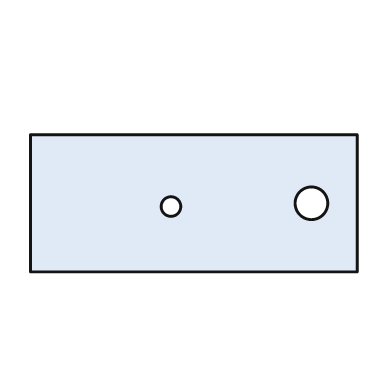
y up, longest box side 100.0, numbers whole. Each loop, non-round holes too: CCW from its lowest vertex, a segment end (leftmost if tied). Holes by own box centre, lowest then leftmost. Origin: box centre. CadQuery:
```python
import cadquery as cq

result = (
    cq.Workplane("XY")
    .moveTo(-50.0, -21.0)
    .lineTo(50.0, -21.0)
    .lineTo(50.0, 21.0)
    .lineTo(-50.0, 21.0)
    .close()
    .moveTo(-7.0, -1.0)
    .circle(3.0)
    .moveTo(36.0, 0.0)
    .circle(5.0)
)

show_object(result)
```